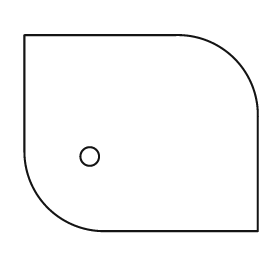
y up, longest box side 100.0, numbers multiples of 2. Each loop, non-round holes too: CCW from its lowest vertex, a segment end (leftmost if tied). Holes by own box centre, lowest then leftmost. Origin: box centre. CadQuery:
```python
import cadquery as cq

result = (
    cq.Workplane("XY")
    .moveTo(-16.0, -42.0)
    .lineTo(50.0, -42.0)
    .lineTo(50.0, 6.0)
    .threePointArc((40.0, 32.0), (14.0, 42.0))
    .lineTo(-50.0, 42.0)
    .lineTo(-50.0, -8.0)
    .threePointArc((-40.0, -32.0), (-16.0, -42.0))
    .close()
    .moveTo(-22.0, -10.0)
    .circle(4.0)
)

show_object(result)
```